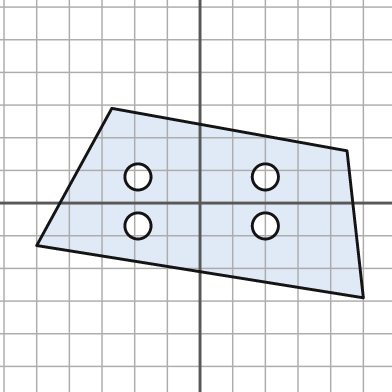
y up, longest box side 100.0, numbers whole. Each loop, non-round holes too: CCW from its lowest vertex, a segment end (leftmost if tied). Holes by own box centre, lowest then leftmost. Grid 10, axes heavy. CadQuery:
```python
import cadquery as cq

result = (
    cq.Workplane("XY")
    .moveTo(50.0, -29.0)
    .lineTo(45.0, 16.0)
    .lineTo(-27.0, 29.0)
    .lineTo(-50.0, -13.0)
    .close()
    .moveTo(-19.0, -7.0)
    .circle(4.0)
    .moveTo(20.0, -7.0)
    .circle(4.0)
    .moveTo(-19.0, 8.0)
    .circle(4.0)
    .moveTo(20.0, 8.0)
    .circle(4.0)
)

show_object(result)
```